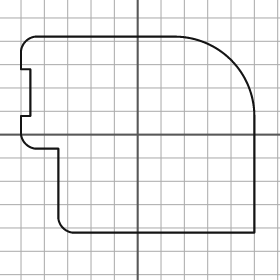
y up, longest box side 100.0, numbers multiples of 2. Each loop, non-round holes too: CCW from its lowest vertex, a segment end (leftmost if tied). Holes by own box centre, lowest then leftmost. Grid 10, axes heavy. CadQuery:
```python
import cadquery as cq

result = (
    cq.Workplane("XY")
    .moveTo(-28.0, -42.0)
    .lineTo(50.0, -42.0)
    .lineTo(50.0, 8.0)
    .threePointArc((40.0, 32.0), (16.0, 42.0))
    .lineTo(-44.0, 42.0)
    .threePointArc((-48.0, 40.0), (-50.0, 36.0))
    .lineTo(-50.0, 28.0)
    .lineTo(-46.0, 28.0)
    .lineTo(-46.0, 8.0)
    .lineTo(-50.0, 8.0)
    .lineTo(-50.0, 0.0)
    .threePointArc((-48.0, -4.0), (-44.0, -6.0))
    .lineTo(-34.0, -6.0)
    .lineTo(-34.0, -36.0)
    .threePointArc((-32.0, -40.0), (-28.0, -42.0))
    .close()
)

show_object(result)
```